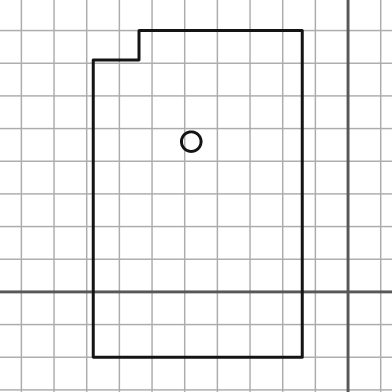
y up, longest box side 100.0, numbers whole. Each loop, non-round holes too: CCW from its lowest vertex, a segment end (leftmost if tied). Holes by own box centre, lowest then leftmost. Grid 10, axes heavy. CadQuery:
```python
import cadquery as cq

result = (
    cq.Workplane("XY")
    .moveTo(-78.0, -20.0)
    .lineTo(-14.0, -20.0)
    .lineTo(-14.0, 80.0)
    .lineTo(-64.0, 80.0)
    .lineTo(-64.0, 71.0)
    .lineTo(-78.0, 71.0)
    .close()
    .moveTo(-48.0, 46.0)
    .circle(3.0)
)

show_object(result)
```